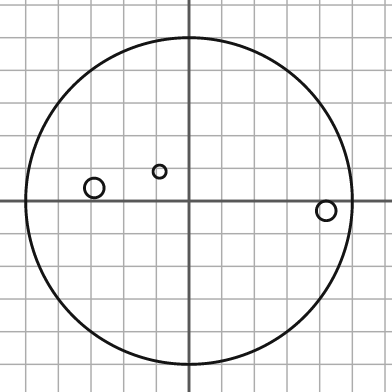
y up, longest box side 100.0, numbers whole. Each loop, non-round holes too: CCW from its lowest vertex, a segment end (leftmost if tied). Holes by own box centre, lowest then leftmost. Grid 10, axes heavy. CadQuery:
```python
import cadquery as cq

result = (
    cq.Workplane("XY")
    .moveTo(0.0, 0.0)
    .circle(50.0)
    .moveTo(42.0, -3.0)
    .circle(3.0)
    .moveTo(-29.0, 4.0)
    .circle(3.0)
    .moveTo(-9.0, 9.0)
    .circle(2.0)
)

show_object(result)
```